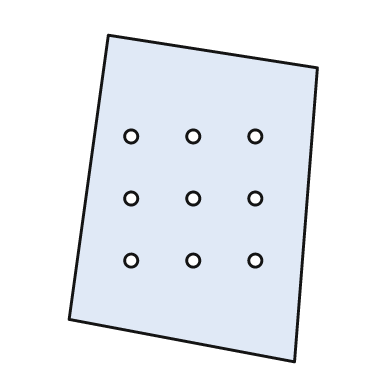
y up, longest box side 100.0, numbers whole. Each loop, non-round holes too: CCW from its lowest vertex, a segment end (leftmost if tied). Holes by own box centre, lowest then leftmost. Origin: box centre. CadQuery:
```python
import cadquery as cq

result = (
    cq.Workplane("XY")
    .moveTo(31.0, -50.0)
    .lineTo(38.0, 40.0)
    .lineTo(-26.0, 50.0)
    .lineTo(-38.0, -37.0)
    .close()
    .moveTo(-19.0, -19.0)
    .circle(2.0)
    .moveTo(0.0, -19.0)
    .circle(2.0)
    .moveTo(19.0, -19.0)
    .circle(2.0)
    .moveTo(-19.0, 0.0)
    .circle(2.0)
    .moveTo(0.0, 0.0)
    .circle(2.0)
    .moveTo(19.0, 0.0)
    .circle(2.0)
    .moveTo(-19.0, 19.0)
    .circle(2.0)
    .moveTo(0.0, 19.0)
    .circle(2.0)
    .moveTo(19.0, 19.0)
    .circle(2.0)
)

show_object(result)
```